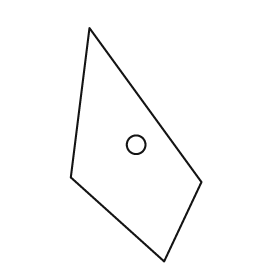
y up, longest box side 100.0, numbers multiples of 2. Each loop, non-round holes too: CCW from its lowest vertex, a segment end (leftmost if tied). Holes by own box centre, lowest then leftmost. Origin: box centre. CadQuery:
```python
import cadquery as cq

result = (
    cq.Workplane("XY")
    .moveTo(12.0, -50.0)
    .lineTo(28.0, -16.0)
    .lineTo(-20.0, 50.0)
    .lineTo(-28.0, -14.0)
    .close()
    .moveTo(0.0, 0.0)
    .circle(4.0)
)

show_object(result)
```